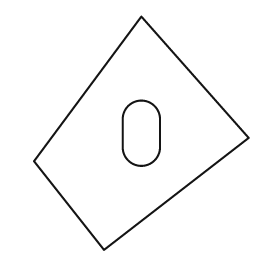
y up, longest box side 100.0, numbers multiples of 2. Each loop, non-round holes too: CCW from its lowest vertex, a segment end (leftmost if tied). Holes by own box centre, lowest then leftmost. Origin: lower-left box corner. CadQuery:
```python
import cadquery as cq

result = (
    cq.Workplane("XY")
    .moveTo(30.0, 0.0)
    .lineTo(92.0, 48.0)
    .lineTo(46.0, 100.0)
    .lineTo(0.0, 38.0)
    .close()
    .moveTo(38.0, 44.0)
    .threePointArc((46.0, 36.0), (54.0, 44.0))
    .lineTo(54.0, 56.0)
    .threePointArc((46.0, 64.0), (38.0, 56.0))
    .close()
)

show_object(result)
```